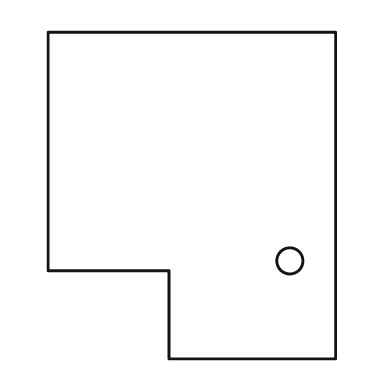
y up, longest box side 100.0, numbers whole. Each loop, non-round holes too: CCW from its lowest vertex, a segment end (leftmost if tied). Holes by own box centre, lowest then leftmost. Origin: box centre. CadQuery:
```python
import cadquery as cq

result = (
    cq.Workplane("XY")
    .moveTo(-7.0, -50.0)
    .lineTo(44.0, -50.0)
    .lineTo(44.0, 50.0)
    .lineTo(-44.0, 50.0)
    .lineTo(-44.0, -23.0)
    .lineTo(-7.0, -23.0)
    .close()
    .moveTo(30.0, -20.0)
    .circle(4.0)
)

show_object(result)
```